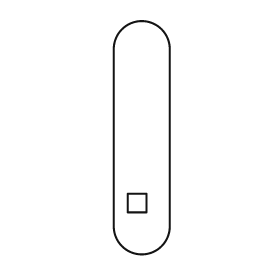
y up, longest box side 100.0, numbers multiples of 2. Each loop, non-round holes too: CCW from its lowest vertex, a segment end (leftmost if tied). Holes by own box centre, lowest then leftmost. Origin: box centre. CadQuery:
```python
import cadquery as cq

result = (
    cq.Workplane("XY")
    .moveTo(-12.0, -38.0)
    .threePointArc((0.0, -50.0), (12.0, -38.0))
    .lineTo(12.0, 38.0)
    .threePointArc((0.0, 50.0), (-12.0, 38.0))
    .close()
    .moveTo(-6.0, -32.0)
    .lineTo(2.0, -32.0)
    .lineTo(2.0, -24.0)
    .lineTo(-6.0, -24.0)
    .close()
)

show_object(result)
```